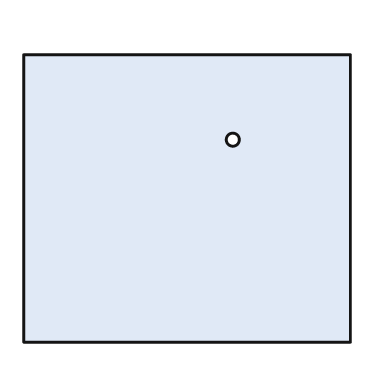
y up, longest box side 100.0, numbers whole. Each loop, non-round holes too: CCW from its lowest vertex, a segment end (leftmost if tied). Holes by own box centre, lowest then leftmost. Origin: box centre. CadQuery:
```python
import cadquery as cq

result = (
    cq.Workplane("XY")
    .moveTo(-50.0, -44.0)
    .lineTo(50.0, -44.0)
    .lineTo(50.0, 44.0)
    .lineTo(-50.0, 44.0)
    .close()
    .moveTo(14.0, 18.0)
    .circle(2.0)
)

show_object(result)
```